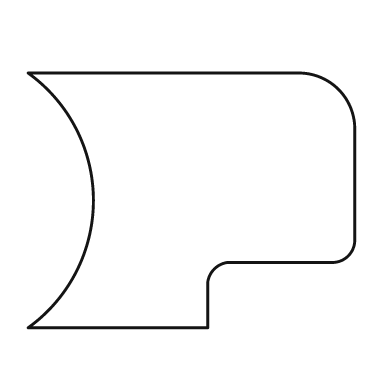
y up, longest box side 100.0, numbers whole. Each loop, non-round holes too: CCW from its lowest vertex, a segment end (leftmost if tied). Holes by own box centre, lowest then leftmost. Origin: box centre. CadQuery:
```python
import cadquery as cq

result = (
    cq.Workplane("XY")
    .moveTo(-50.0, -39.0)
    .lineTo(5.0, -39.0)
    .lineTo(5.0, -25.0)
    .threePointArc((7.0, -21.0), (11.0, -19.0))
    .lineTo(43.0, -19.0)
    .threePointArc((48.0, -17.0), (50.0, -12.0))
    .lineTo(50.0, 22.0)
    .threePointArc((45.0, 34.0), (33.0, 39.0))
    .lineTo(-50.0, 39.0)
    .threePointArc((-30.0, 0.0), (-50.0, -39.0))
    .close()
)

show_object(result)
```